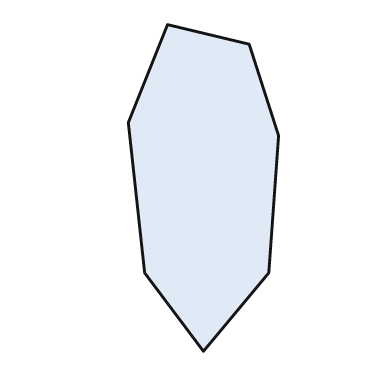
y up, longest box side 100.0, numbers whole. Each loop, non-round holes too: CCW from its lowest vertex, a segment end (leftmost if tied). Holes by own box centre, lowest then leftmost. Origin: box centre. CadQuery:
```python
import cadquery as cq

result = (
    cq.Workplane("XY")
    .moveTo(0.0, -50.0)
    .lineTo(20.0, -26.0)
    .lineTo(23.0, 16.0)
    .lineTo(14.0, 44.0)
    .lineTo(-11.0, 50.0)
    .lineTo(-23.0, 20.0)
    .lineTo(-18.0, -26.0)
    .close()
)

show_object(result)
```